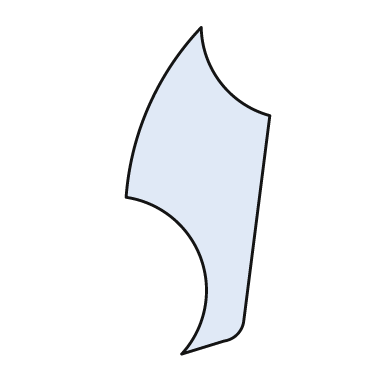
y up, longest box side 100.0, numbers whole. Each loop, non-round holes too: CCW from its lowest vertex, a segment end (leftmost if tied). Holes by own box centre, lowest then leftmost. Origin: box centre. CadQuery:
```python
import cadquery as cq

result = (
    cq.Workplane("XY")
    .moveTo(-5.0, -50.0)
    .lineTo(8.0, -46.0)
    .threePointArc((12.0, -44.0), (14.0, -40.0))
    .lineTo(22.0, 23.0)
    .threePointArc((7.0, 33.0), (1.0, 50.0))
    .threePointArc((-15.0, 26.0), (-22.0, -2.0))
    .threePointArc((1.0, -21.0), (-5.0, -50.0))
    .close()
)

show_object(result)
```